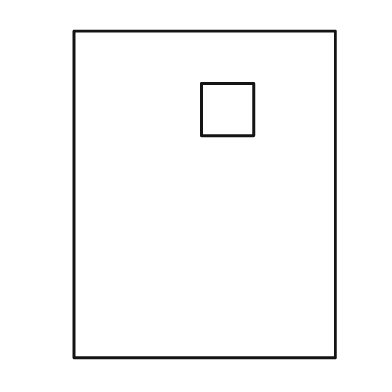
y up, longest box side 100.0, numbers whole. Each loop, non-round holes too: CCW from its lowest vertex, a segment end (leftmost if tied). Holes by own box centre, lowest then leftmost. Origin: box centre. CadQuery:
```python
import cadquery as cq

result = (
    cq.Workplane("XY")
    .moveTo(-40.0, -50.0)
    .lineTo(40.0, -50.0)
    .lineTo(40.0, 50.0)
    .lineTo(-40.0, 50.0)
    .close()
    .moveTo(-1.0, 18.0)
    .lineTo(15.0, 18.0)
    .lineTo(15.0, 34.0)
    .lineTo(-1.0, 34.0)
    .close()
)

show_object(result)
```